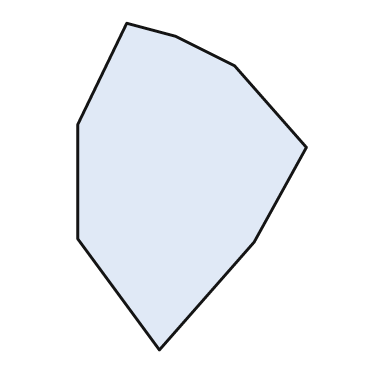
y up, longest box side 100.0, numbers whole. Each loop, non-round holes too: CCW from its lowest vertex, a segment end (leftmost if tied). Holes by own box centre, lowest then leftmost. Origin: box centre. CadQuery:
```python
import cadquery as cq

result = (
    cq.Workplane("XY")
    .moveTo(-10.0, -50.0)
    .lineTo(19.0, -17.0)
    .lineTo(35.0, 12.0)
    .lineTo(13.0, 37.0)
    .lineTo(-5.0, 46.0)
    .lineTo(-20.0, 50.0)
    .lineTo(-35.0, 19.0)
    .lineTo(-35.0, -16.0)
    .close()
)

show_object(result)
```